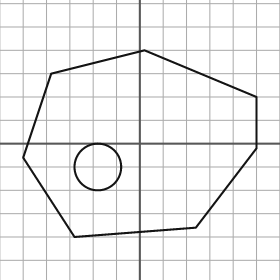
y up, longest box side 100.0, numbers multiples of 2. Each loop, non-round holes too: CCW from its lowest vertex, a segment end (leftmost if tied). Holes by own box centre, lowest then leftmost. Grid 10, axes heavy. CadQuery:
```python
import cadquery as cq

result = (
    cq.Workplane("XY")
    .moveTo(-28.0, -40.0)
    .lineTo(24.0, -36.0)
    .lineTo(50.0, -2.0)
    .lineTo(50.0, 20.0)
    .lineTo(2.0, 40.0)
    .lineTo(-38.0, 30.0)
    .lineTo(-50.0, -6.0)
    .close()
    .moveTo(-18.0, -10.0)
    .circle(10.0)
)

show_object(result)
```